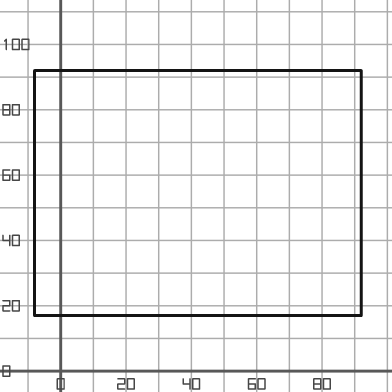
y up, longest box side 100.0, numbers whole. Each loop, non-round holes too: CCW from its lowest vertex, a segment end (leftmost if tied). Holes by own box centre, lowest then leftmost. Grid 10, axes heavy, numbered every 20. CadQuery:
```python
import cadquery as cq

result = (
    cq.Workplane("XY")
    .moveTo(-8.0, 17.0)
    .lineTo(92.0, 17.0)
    .lineTo(92.0, 92.0)
    .lineTo(-8.0, 92.0)
    .close()
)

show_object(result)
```